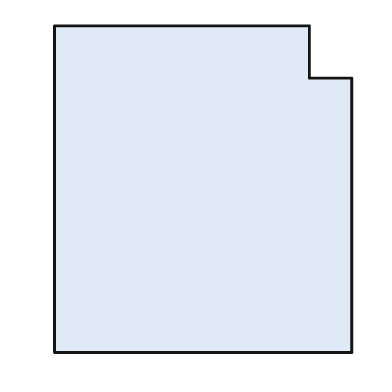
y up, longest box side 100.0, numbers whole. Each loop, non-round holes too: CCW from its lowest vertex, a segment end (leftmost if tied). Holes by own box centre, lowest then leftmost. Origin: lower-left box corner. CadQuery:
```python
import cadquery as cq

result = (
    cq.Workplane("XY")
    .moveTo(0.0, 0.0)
    .lineTo(91.0, 0.0)
    .lineTo(91.0, 84.0)
    .lineTo(78.0, 84.0)
    .lineTo(78.0, 100.0)
    .lineTo(0.0, 100.0)
    .close()
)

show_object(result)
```